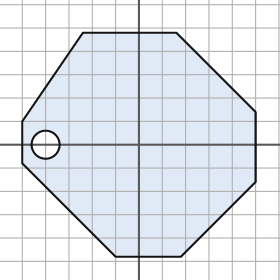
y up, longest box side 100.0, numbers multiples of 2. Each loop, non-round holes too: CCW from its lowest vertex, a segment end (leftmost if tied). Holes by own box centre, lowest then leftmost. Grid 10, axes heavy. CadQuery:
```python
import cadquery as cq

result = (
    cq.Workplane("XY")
    .moveTo(-10.0, -48.0)
    .lineTo(18.0, -48.0)
    .lineTo(50.0, -16.0)
    .lineTo(50.0, 14.0)
    .lineTo(16.0, 48.0)
    .lineTo(-24.0, 48.0)
    .lineTo(-50.0, 10.0)
    .lineTo(-50.0, -8.0)
    .close()
    .moveTo(-40.0, 0.0)
    .circle(6.0)
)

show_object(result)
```